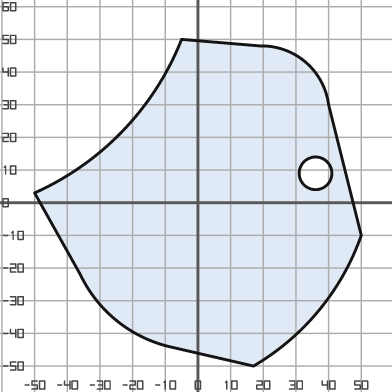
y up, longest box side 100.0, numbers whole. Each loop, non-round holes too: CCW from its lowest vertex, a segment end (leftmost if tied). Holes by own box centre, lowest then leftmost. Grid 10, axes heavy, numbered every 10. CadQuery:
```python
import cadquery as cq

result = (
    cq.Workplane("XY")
    .moveTo(17.0, -50.0)
    .threePointArc((37.0, -33.0), (50.0, -10.0))
    .lineTo(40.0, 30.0)
    .threePointArc((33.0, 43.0), (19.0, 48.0))
    .lineTo(-5.0, 50.0)
    .threePointArc((-23.0, 22.0), (-50.0, 3.0))
    .lineTo(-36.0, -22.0)
    .threePointArc((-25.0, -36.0), (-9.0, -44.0))
    .close()
    .moveTo(36.0, 9.0)
    .circle(5.0)
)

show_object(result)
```